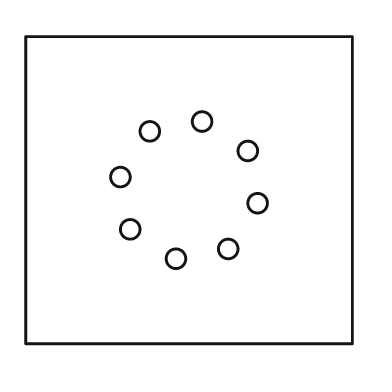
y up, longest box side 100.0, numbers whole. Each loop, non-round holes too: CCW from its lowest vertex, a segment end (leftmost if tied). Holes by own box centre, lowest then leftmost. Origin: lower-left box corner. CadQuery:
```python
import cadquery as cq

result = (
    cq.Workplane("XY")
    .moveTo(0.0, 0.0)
    .lineTo(100.0, 0.0)
    .lineTo(100.0, 94.0)
    .lineTo(0.0, 94.0)
    .close()
    .moveTo(46.0, 26.0)
    .circle(3.0)
    .moveTo(62.0, 29.0)
    .circle(3.0)
    .moveTo(32.0, 35.0)
    .circle(3.0)
    .moveTo(71.0, 43.0)
    .circle(3.0)
    .moveTo(29.0, 51.0)
    .circle(3.0)
    .moveTo(68.0, 59.0)
    .circle(3.0)
    .moveTo(38.0, 65.0)
    .circle(3.0)
    .moveTo(54.0, 68.0)
    .circle(3.0)
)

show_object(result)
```